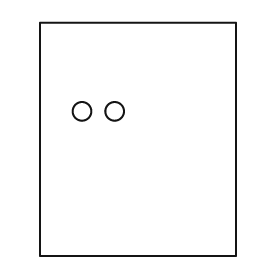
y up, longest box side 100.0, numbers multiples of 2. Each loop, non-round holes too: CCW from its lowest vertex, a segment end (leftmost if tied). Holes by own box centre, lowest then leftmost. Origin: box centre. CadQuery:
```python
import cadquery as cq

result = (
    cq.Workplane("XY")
    .moveTo(-42.0, -50.0)
    .lineTo(42.0, -50.0)
    .lineTo(42.0, 50.0)
    .lineTo(-42.0, 50.0)
    .close()
    .moveTo(-24.0, 12.0)
    .circle(4.0)
    .moveTo(-10.0, 12.0)
    .circle(4.0)
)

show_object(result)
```